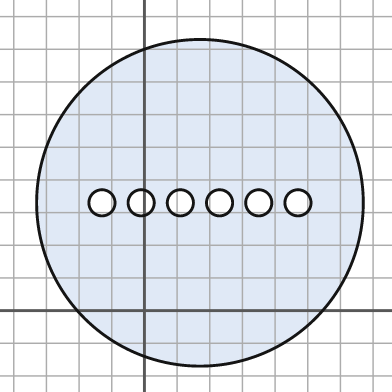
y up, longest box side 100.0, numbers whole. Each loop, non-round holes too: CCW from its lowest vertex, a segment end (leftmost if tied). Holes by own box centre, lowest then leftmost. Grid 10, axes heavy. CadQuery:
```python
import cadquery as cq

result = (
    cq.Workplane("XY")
    .moveTo(17.0, 33.0)
    .circle(50.0)
    .moveTo(-13.0, 33.0)
    .circle(4.0)
    .moveTo(-1.0, 33.0)
    .circle(4.0)
    .moveTo(11.0, 33.0)
    .circle(4.0)
    .moveTo(23.0, 33.0)
    .circle(4.0)
    .moveTo(35.0, 33.0)
    .circle(4.0)
    .moveTo(47.0, 33.0)
    .circle(4.0)
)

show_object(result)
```